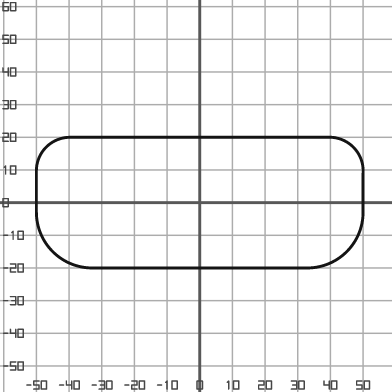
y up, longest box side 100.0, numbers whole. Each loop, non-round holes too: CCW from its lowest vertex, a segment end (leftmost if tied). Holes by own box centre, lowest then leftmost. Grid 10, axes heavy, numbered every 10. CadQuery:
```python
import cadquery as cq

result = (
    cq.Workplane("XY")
    .moveTo(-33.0, -20.0)
    .lineTo(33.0, -20.0)
    .threePointArc((45.0, -15.0), (50.0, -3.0))
    .lineTo(50.0, 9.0)
    .threePointArc((47.0, 17.0), (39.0, 20.0))
    .lineTo(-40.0, 20.0)
    .threePointArc((-47.0, 17.0), (-50.0, 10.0))
    .lineTo(-50.0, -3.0)
    .threePointArc((-45.0, -15.0), (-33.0, -20.0))
    .close()
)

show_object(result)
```